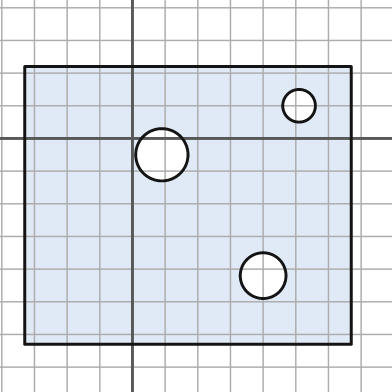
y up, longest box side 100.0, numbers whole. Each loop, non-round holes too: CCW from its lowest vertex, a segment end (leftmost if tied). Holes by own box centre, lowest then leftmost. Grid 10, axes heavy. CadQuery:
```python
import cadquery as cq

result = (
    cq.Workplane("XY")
    .moveTo(-33.0, -63.0)
    .lineTo(67.0, -63.0)
    .lineTo(67.0, 22.0)
    .lineTo(-33.0, 22.0)
    .close()
    .moveTo(40.0, -42.0)
    .circle(7.0)
    .moveTo(9.0, -5.0)
    .circle(8.0)
    .moveTo(51.0, 10.0)
    .circle(5.0)
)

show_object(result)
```